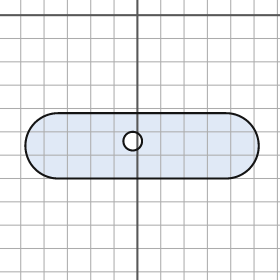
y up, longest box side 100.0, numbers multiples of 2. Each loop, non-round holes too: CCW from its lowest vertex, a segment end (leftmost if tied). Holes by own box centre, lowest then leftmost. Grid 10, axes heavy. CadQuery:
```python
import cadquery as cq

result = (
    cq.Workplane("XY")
    .moveTo(-34.0, -70.0)
    .lineTo(38.0, -70.0)
    .threePointArc((52.0, -56.0), (38.0, -42.0))
    .lineTo(-34.0, -42.0)
    .threePointArc((-48.0, -56.0), (-34.0, -70.0))
    .close()
    .moveTo(-2.0, -54.0)
    .circle(4.0)
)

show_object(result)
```